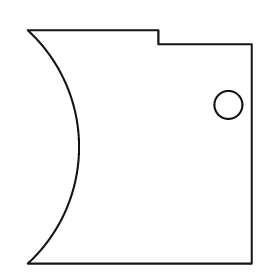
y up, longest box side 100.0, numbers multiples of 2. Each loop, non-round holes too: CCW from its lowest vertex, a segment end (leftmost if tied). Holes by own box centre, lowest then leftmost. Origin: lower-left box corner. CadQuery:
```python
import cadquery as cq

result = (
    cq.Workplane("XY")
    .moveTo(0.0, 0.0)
    .lineTo(96.0, 0.0)
    .lineTo(96.0, 94.0)
    .lineTo(56.0, 94.0)
    .lineTo(56.0, 100.0)
    .lineTo(0.0, 100.0)
    .threePointArc((22.0, 50.0), (0.0, 0.0))
    .close()
    .moveTo(86.0, 68.0)
    .circle(6.0)
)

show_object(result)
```